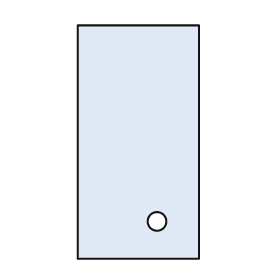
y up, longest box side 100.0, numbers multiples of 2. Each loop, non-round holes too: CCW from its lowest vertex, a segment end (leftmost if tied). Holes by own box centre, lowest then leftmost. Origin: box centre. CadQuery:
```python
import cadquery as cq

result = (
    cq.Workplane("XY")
    .moveTo(-26.0, -50.0)
    .lineTo(26.0, -50.0)
    .lineTo(26.0, 50.0)
    .lineTo(-26.0, 50.0)
    .close()
    .moveTo(8.0, -34.0)
    .circle(4.0)
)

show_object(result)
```